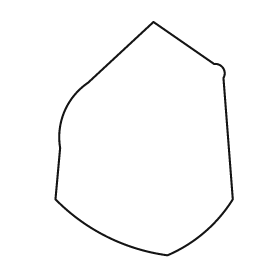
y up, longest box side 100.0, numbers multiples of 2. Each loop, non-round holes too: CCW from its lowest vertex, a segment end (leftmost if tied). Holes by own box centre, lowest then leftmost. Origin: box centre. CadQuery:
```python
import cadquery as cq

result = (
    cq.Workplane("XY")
    .moveTo(10.0, -50.0)
    .threePointArc((26.0, -40.0), (38.0, -26.0))
    .lineTo(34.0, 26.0)
    .threePointArc((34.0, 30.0), (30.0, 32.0))
    .lineTo(4.0, 50.0)
    .lineTo(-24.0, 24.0)
    .threePointArc((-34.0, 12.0), (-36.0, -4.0))
    .lineTo(-38.0, -26.0)
    .threePointArc((-16.0, -42.0), (10.0, -50.0))
    .close()
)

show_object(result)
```